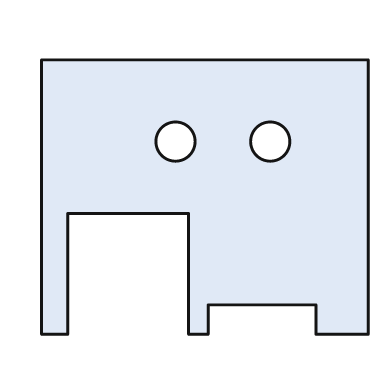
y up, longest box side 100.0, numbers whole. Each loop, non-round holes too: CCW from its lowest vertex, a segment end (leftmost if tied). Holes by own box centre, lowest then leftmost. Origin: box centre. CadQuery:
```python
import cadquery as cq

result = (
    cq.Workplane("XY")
    .moveTo(-50.0, -42.0)
    .lineTo(-42.0, -42.0)
    .lineTo(-42.0, -5.0)
    .lineTo(-5.0, -5.0)
    .lineTo(-5.0, -42.0)
    .lineTo(1.0, -42.0)
    .lineTo(1.0, -33.0)
    .lineTo(34.0, -33.0)
    .lineTo(34.0, -42.0)
    .lineTo(50.0, -42.0)
    .lineTo(50.0, 42.0)
    .lineTo(-50.0, 42.0)
    .close()
    .moveTo(-9.0, 17.0)
    .circle(6.0)
    .moveTo(20.0, 17.0)
    .circle(6.0)
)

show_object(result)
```